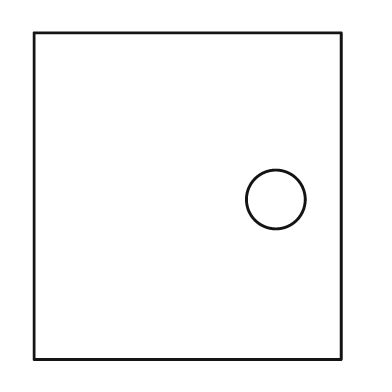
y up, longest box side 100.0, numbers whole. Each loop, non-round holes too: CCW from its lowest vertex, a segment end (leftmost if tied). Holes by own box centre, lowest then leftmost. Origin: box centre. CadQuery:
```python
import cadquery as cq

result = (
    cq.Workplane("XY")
    .moveTo(-47.0, -50.0)
    .lineTo(47.0, -50.0)
    .lineTo(47.0, 50.0)
    .lineTo(-47.0, 50.0)
    .close()
    .moveTo(27.0, -1.0)
    .circle(9.0)
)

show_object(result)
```